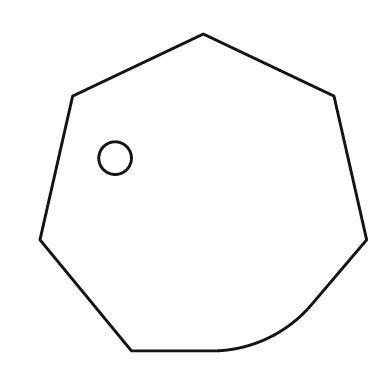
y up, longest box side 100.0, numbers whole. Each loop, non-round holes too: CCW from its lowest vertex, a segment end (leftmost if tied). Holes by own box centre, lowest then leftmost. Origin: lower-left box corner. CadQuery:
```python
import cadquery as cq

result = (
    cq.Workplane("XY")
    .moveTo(28.0, 0.0)
    .lineTo(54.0, 0.0)
    .threePointArc((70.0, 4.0), (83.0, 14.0))
    .lineTo(100.0, 34.0)
    .lineTo(90.0, 78.0)
    .lineTo(50.0, 97.0)
    .lineTo(10.0, 78.0)
    .lineTo(0.0, 34.0)
    .close()
    .moveTo(23.0, 59.0)
    .circle(5.0)
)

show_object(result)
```